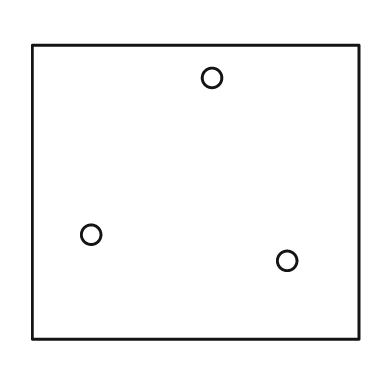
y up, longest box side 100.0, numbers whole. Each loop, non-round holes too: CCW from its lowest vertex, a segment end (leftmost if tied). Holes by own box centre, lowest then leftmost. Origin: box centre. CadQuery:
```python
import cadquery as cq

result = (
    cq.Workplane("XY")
    .moveTo(-50.0, -45.0)
    .lineTo(50.0, -45.0)
    .lineTo(50.0, 45.0)
    .lineTo(-50.0, 45.0)
    .close()
    .moveTo(28.0, -21.0)
    .circle(3.0)
    .moveTo(-32.0, -13.0)
    .circle(3.0)
    .moveTo(5.0, 35.0)
    .circle(3.0)
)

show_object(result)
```